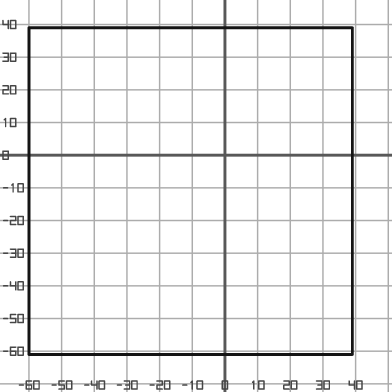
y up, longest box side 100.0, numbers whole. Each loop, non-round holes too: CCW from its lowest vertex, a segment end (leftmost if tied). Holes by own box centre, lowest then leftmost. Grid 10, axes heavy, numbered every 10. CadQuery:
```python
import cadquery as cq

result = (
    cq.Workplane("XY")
    .moveTo(-60.0, -61.0)
    .lineTo(39.0, -61.0)
    .lineTo(39.0, 39.0)
    .lineTo(-60.0, 39.0)
    .close()
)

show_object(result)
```